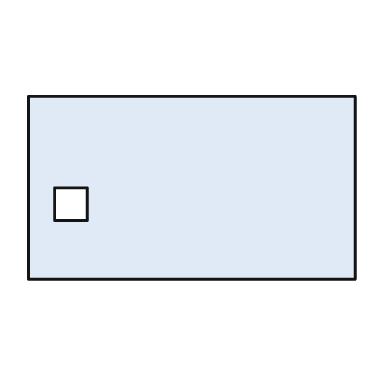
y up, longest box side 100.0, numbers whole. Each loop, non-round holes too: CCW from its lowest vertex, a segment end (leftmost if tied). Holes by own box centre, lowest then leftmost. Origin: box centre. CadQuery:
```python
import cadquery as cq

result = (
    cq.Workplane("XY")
    .moveTo(-50.0, -28.0)
    .lineTo(50.0, -28.0)
    .lineTo(50.0, 28.0)
    .lineTo(-50.0, 28.0)
    .close()
    .moveTo(-42.0, -10.0)
    .lineTo(-32.0, -10.0)
    .lineTo(-32.0, 0.0)
    .lineTo(-42.0, 0.0)
    .close()
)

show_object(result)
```